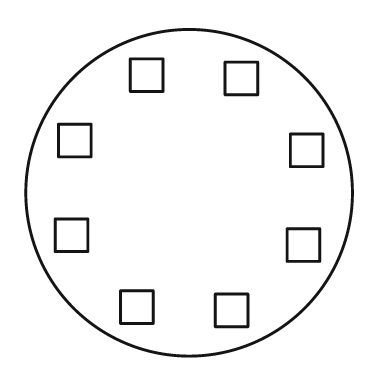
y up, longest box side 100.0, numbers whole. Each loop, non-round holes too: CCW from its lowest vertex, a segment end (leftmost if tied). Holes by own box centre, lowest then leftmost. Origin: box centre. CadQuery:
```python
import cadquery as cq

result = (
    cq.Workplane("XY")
    .moveTo(0.0, 0.0)
    .circle(50.0)
    .moveTo(8.0, -41.0)
    .lineTo(18.0, -41.0)
    .lineTo(18.0, -31.0)
    .lineTo(8.0, -31.0)
    .close()
    .moveTo(-21.0, -40.0)
    .lineTo(-11.0, -40.0)
    .lineTo(-11.0, -30.0)
    .lineTo(-21.0, -30.0)
    .close()
    .moveTo(30.0, -21.0)
    .lineTo(40.0, -21.0)
    .lineTo(40.0, -11.0)
    .lineTo(30.0, -11.0)
    .close()
    .moveTo(-41.0, -18.0)
    .lineTo(-31.0, -18.0)
    .lineTo(-31.0, -8.0)
    .lineTo(-41.0, -8.0)
    .close()
    .moveTo(31.0, 8.0)
    .lineTo(41.0, 8.0)
    .lineTo(41.0, 18.0)
    .lineTo(31.0, 18.0)
    .close()
    .moveTo(-40.0, 11.0)
    .lineTo(-30.0, 11.0)
    .lineTo(-30.0, 21.0)
    .lineTo(-40.0, 21.0)
    .close()
    .moveTo(11.0, 30.0)
    .lineTo(21.0, 30.0)
    .lineTo(21.0, 40.0)
    .lineTo(11.0, 40.0)
    .close()
    .moveTo(-18.0, 31.0)
    .lineTo(-8.0, 31.0)
    .lineTo(-8.0, 41.0)
    .lineTo(-18.0, 41.0)
    .close()
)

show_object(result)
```